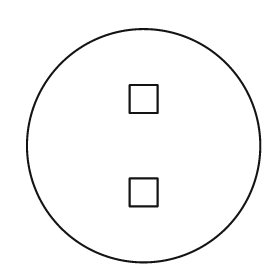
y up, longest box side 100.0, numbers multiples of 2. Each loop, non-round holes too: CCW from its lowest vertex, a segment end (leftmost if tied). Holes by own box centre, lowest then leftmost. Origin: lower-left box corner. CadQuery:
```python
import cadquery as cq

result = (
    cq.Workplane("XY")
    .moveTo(50.0, 50.0)
    .circle(50.0)
    .moveTo(44.0, 24.0)
    .lineTo(56.0, 24.0)
    .lineTo(56.0, 36.0)
    .lineTo(44.0, 36.0)
    .close()
    .moveTo(44.0, 64.0)
    .lineTo(56.0, 64.0)
    .lineTo(56.0, 76.0)
    .lineTo(44.0, 76.0)
    .close()
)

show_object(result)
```